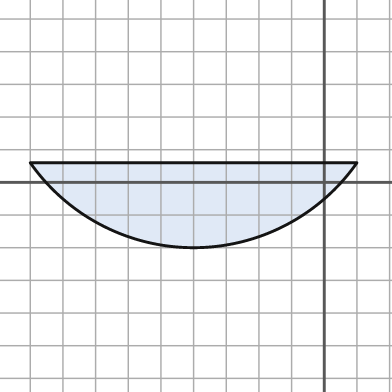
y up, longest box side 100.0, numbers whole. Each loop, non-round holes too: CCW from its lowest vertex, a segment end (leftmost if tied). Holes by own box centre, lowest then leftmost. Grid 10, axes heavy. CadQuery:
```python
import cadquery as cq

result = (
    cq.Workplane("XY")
    .moveTo(-90.0, 6.0)
    .threePointArc((-40.0, -20.0), (10.0, 6.0))
    .close()
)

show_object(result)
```